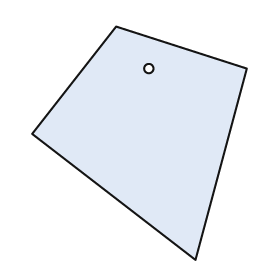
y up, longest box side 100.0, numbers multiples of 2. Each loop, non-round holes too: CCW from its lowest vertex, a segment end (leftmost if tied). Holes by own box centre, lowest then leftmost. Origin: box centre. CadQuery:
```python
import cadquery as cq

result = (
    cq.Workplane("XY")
    .moveTo(24.0, -50.0)
    .lineTo(46.0, 32.0)
    .lineTo(-10.0, 50.0)
    .lineTo(-46.0, 4.0)
    .close()
    .moveTo(4.0, 32.0)
    .circle(2.0)
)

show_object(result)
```